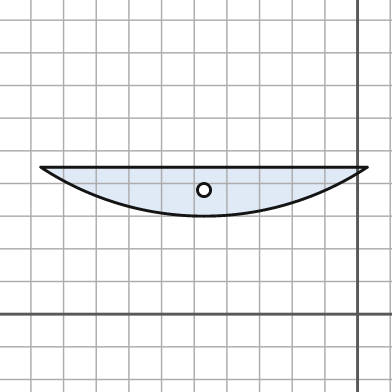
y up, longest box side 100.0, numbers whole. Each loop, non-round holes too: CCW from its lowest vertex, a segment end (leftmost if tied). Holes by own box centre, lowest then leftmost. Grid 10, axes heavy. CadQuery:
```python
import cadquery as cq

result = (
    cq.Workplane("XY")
    .moveTo(-97.0, 45.0)
    .threePointArc((-47.0, 30.0), (3.0, 45.0))
    .close()
    .moveTo(-47.0, 38.0)
    .circle(2.0)
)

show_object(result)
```